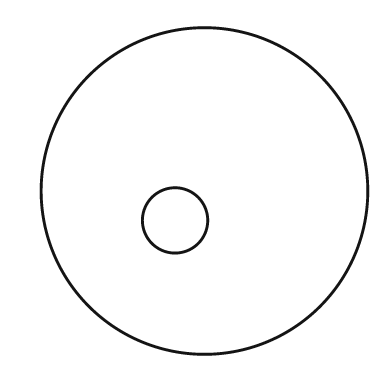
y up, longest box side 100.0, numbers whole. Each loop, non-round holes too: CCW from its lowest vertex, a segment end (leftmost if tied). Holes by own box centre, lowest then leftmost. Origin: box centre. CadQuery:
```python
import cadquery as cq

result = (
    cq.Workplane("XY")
    .moveTo(0.0, 0.0)
    .circle(50.0)
    .moveTo(-9.0, -9.0)
    .circle(10.0)
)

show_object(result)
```